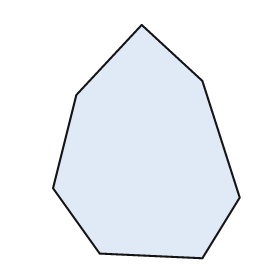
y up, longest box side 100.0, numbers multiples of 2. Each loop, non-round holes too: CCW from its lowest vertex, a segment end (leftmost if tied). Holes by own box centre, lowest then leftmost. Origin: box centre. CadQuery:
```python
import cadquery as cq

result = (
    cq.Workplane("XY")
    .moveTo(24.0, -50.0)
    .lineTo(40.0, -24.0)
    .lineTo(24.0, 26.0)
    .lineTo(-2.0, 50.0)
    .lineTo(-30.0, 20.0)
    .lineTo(-40.0, -20.0)
    .lineTo(-20.0, -48.0)
    .close()
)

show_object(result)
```